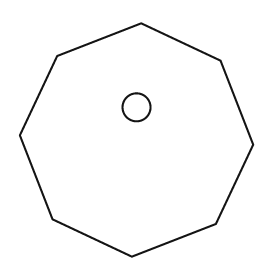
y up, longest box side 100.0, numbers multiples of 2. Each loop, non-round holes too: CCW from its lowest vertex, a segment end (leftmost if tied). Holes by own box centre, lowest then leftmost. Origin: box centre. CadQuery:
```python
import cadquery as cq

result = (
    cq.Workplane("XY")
    .moveTo(-2.0, -50.0)
    .lineTo(34.0, -36.0)
    .lineTo(50.0, -2.0)
    .lineTo(36.0, 34.0)
    .lineTo(2.0, 50.0)
    .lineTo(-34.0, 36.0)
    .lineTo(-50.0, 2.0)
    .lineTo(-36.0, -34.0)
    .close()
    .moveTo(0.0, 14.0)
    .circle(6.0)
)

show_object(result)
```